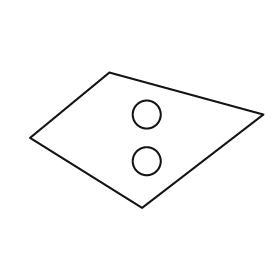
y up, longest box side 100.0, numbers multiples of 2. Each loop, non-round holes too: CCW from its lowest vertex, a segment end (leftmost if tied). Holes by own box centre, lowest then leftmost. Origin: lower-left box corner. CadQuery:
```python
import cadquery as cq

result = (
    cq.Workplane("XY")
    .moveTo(48.0, 0.0)
    .lineTo(100.0, 40.0)
    .lineTo(34.0, 58.0)
    .lineTo(0.0, 30.0)
    .close()
    .moveTo(50.0, 20.0)
    .circle(6.0)
    .moveTo(50.0, 40.0)
    .circle(6.0)
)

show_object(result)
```